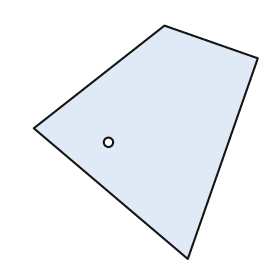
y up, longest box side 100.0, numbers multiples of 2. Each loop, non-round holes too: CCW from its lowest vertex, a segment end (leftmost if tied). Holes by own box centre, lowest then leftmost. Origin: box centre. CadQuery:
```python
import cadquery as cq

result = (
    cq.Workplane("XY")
    .moveTo(18.0, -50.0)
    .lineTo(48.0, 36.0)
    .lineTo(8.0, 50.0)
    .lineTo(-48.0, 6.0)
    .close()
    .moveTo(-16.0, 0.0)
    .circle(2.0)
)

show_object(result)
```